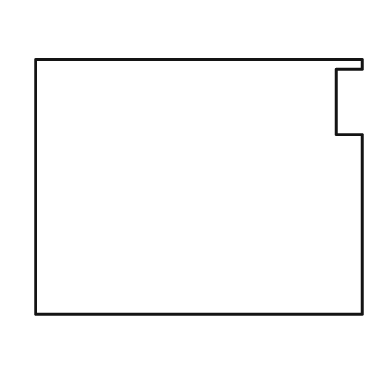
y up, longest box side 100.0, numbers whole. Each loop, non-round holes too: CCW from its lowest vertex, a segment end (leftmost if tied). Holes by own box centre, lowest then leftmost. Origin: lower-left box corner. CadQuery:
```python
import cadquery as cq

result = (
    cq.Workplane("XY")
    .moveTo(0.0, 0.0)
    .lineTo(100.0, 0.0)
    .lineTo(100.0, 55.0)
    .lineTo(92.0, 55.0)
    .lineTo(92.0, 75.0)
    .lineTo(100.0, 75.0)
    .lineTo(100.0, 78.0)
    .lineTo(0.0, 78.0)
    .close()
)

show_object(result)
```